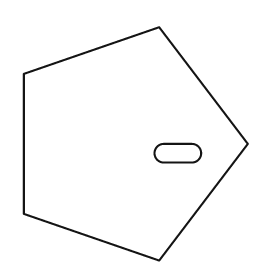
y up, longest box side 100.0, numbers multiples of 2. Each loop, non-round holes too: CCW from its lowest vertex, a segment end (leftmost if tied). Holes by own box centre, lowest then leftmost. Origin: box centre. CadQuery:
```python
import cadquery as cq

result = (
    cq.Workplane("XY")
    .moveTo(10.0, -50.0)
    .lineTo(48.0, 0.0)
    .lineTo(10.0, 50.0)
    .lineTo(-48.0, 30.0)
    .lineTo(-48.0, -30.0)
    .close()
    .moveTo(12.0, -8.0)
    .lineTo(24.0, -8.0)
    .threePointArc((28.0, -4.0), (24.0, 0.0))
    .lineTo(12.0, 0.0)
    .threePointArc((8.0, -4.0), (12.0, -8.0))
    .close()
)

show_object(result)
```